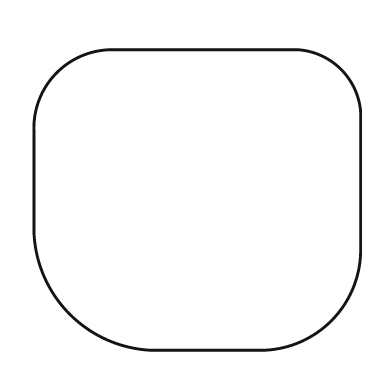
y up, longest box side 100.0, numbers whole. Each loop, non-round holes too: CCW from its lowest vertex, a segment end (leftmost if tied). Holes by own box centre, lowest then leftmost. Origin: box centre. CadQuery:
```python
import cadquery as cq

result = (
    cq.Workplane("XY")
    .moveTo(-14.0, -46.0)
    .lineTo(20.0, -46.0)
    .threePointArc((41.0, -37.0), (50.0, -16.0))
    .lineTo(50.0, 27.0)
    .threePointArc((44.0, 40.0), (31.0, 46.0))
    .lineTo(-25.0, 46.0)
    .threePointArc((-43.0, 39.0), (-50.0, 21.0))
    .lineTo(-50.0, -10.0)
    .threePointArc((-39.0, -35.0), (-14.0, -46.0))
    .close()
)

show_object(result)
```